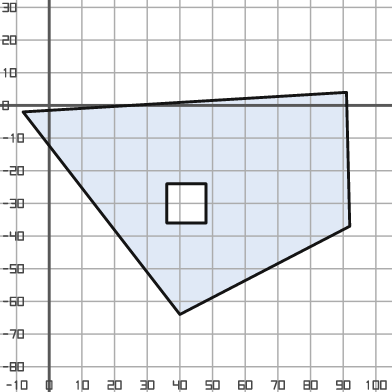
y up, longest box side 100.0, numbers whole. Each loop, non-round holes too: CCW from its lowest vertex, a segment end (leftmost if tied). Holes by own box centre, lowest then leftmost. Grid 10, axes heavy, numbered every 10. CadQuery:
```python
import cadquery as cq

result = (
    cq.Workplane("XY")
    .moveTo(40.0, -64.0)
    .lineTo(92.0, -37.0)
    .lineTo(91.0, 4.0)
    .lineTo(-8.0, -2.0)
    .close()
    .moveTo(36.0, -36.0)
    .lineTo(48.0, -36.0)
    .lineTo(48.0, -24.0)
    .lineTo(36.0, -24.0)
    .close()
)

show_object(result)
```